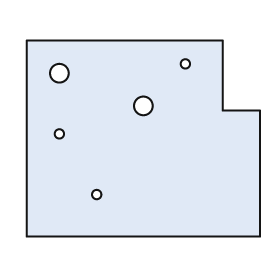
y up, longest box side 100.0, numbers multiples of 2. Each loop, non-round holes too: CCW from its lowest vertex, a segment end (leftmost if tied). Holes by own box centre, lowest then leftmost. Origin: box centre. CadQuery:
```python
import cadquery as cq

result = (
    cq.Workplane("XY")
    .moveTo(-50.0, -42.0)
    .lineTo(50.0, -42.0)
    .lineTo(50.0, 12.0)
    .lineTo(34.0, 12.0)
    .lineTo(34.0, 42.0)
    .lineTo(-50.0, 42.0)
    .close()
    .moveTo(-20.0, -24.0)
    .circle(2.0)
    .moveTo(-36.0, 2.0)
    .circle(2.0)
    .moveTo(0.0, 14.0)
    .circle(4.0)
    .moveTo(-36.0, 28.0)
    .circle(4.0)
    .moveTo(18.0, 32.0)
    .circle(2.0)
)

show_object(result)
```